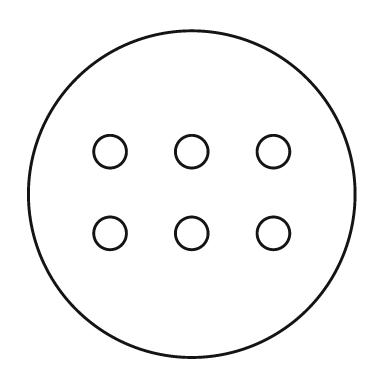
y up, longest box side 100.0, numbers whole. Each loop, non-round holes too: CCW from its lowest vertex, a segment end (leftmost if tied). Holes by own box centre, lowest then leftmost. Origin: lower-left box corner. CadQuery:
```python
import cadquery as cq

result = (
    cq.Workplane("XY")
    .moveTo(50.0, 50.0)
    .circle(50.0)
    .moveTo(25.0, 38.0)
    .circle(5.0)
    .moveTo(50.0, 38.0)
    .circle(5.0)
    .moveTo(75.0, 38.0)
    .circle(5.0)
    .moveTo(25.0, 63.0)
    .circle(5.0)
    .moveTo(50.0, 63.0)
    .circle(5.0)
    .moveTo(75.0, 63.0)
    .circle(5.0)
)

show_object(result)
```